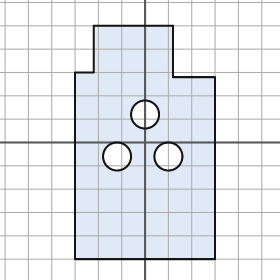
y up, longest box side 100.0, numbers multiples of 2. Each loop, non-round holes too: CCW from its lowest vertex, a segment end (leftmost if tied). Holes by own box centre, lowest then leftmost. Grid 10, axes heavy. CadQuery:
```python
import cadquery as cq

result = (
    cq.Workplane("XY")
    .moveTo(-30.0, -50.0)
    .lineTo(30.0, -50.0)
    .lineTo(30.0, 28.0)
    .lineTo(12.0, 28.0)
    .lineTo(12.0, 50.0)
    .lineTo(-22.0, 50.0)
    .lineTo(-22.0, 30.0)
    .lineTo(-30.0, 30.0)
    .close()
    .moveTo(-12.0, -6.0)
    .circle(6.0)
    .moveTo(10.0, -6.0)
    .circle(6.0)
    .moveTo(0.0, 12.0)
    .circle(6.0)
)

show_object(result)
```